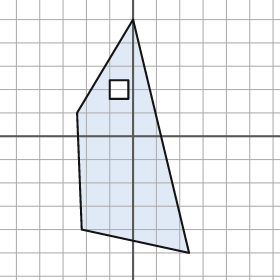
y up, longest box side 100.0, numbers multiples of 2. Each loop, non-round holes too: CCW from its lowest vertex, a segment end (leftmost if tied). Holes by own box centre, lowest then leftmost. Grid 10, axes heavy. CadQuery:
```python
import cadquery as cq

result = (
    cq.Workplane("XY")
    .moveTo(24.0, -50.0)
    .lineTo(0.0, 50.0)
    .lineTo(-24.0, 10.0)
    .lineTo(-22.0, -40.0)
    .close()
    .moveTo(-10.0, 16.0)
    .lineTo(-2.0, 16.0)
    .lineTo(-2.0, 24.0)
    .lineTo(-10.0, 24.0)
    .close()
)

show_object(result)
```